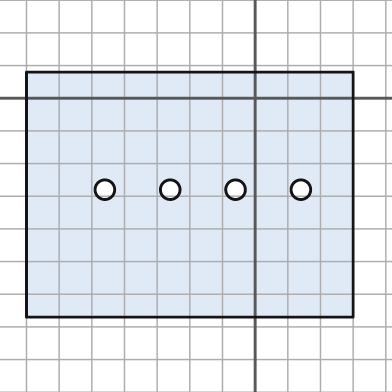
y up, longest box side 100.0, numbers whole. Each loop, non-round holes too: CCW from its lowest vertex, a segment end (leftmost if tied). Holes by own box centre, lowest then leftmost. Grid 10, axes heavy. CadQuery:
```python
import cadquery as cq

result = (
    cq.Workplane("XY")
    .moveTo(-70.0, -67.0)
    .lineTo(30.0, -67.0)
    .lineTo(30.0, 8.0)
    .lineTo(-70.0, 8.0)
    .close()
    .moveTo(-46.0, -28.0)
    .circle(3.0)
    .moveTo(-26.0, -28.0)
    .circle(3.0)
    .moveTo(-6.0, -28.0)
    .circle(3.0)
    .moveTo(14.0, -28.0)
    .circle(3.0)
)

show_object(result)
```